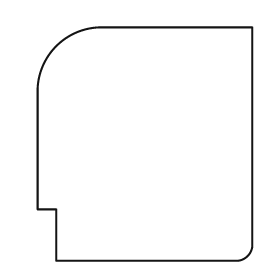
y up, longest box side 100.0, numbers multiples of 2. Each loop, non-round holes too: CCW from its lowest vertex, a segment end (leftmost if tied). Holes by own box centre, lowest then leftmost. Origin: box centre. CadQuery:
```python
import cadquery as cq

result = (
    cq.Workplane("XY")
    .moveTo(-38.0, -50.0)
    .lineTo(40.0, -50.0)
    .threePointArc((44.0, -48.0), (46.0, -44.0))
    .lineTo(46.0, 50.0)
    .lineTo(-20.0, 50.0)
    .threePointArc((-38.0, 42.0), (-46.0, 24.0))
    .lineTo(-46.0, -28.0)
    .lineTo(-38.0, -28.0)
    .close()
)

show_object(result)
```